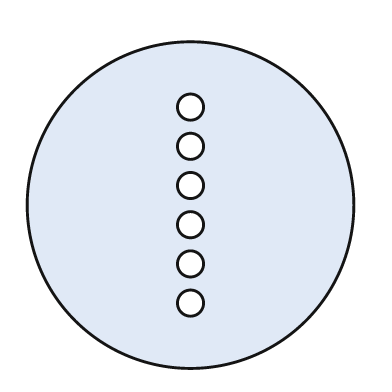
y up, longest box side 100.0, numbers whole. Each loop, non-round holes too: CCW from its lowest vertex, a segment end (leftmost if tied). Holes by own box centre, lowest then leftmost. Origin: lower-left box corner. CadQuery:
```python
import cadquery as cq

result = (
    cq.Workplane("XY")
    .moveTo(50.0, 50.0)
    .circle(50.0)
    .moveTo(50.0, 20.0)
    .circle(4.0)
    .moveTo(50.0, 32.0)
    .circle(4.0)
    .moveTo(50.0, 44.0)
    .circle(4.0)
    .moveTo(50.0, 56.0)
    .circle(4.0)
    .moveTo(50.0, 68.0)
    .circle(4.0)
    .moveTo(50.0, 80.0)
    .circle(4.0)
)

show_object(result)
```